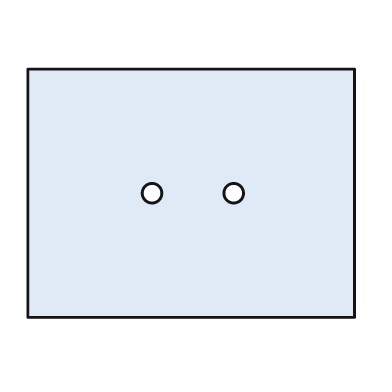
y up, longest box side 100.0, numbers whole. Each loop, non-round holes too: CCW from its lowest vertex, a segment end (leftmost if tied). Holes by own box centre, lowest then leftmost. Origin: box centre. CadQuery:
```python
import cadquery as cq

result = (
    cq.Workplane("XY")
    .moveTo(-50.0, -38.0)
    .lineTo(50.0, -38.0)
    .lineTo(50.0, 38.0)
    .lineTo(-50.0, 38.0)
    .close()
    .moveTo(-12.0, 0.0)
    .circle(3.0)
    .moveTo(13.0, 0.0)
    .circle(3.0)
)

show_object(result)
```